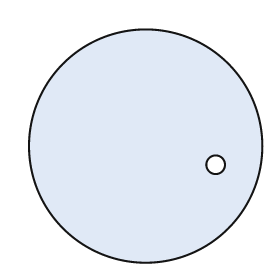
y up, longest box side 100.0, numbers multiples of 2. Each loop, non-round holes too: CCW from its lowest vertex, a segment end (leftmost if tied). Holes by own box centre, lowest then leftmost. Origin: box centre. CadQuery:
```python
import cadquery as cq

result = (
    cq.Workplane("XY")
    .moveTo(0.0, 0.0)
    .circle(50.0)
    .moveTo(30.0, -8.0)
    .circle(4.0)
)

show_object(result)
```